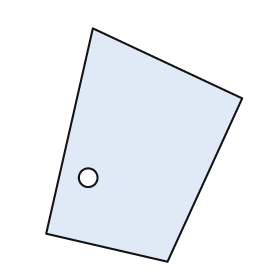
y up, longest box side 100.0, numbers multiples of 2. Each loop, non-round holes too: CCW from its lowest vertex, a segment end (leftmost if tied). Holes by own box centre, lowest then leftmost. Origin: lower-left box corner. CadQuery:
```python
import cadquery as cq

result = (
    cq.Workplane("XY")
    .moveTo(52.0, 0.0)
    .lineTo(84.0, 70.0)
    .lineTo(20.0, 100.0)
    .lineTo(0.0, 12.0)
    .close()
    .moveTo(18.0, 36.0)
    .circle(4.0)
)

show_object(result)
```